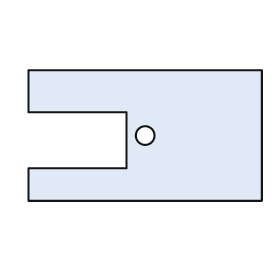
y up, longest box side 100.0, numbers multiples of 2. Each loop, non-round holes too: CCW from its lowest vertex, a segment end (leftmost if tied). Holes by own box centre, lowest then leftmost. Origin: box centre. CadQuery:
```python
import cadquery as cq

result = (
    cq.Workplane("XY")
    .moveTo(-50.0, -28.0)
    .lineTo(50.0, -28.0)
    .lineTo(50.0, 28.0)
    .lineTo(-50.0, 28.0)
    .lineTo(-50.0, 10.0)
    .lineTo(-8.0, 10.0)
    .lineTo(-8.0, -14.0)
    .lineTo(-50.0, -14.0)
    .close()
    .moveTo(0.0, 0.0)
    .circle(4.0)
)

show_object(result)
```